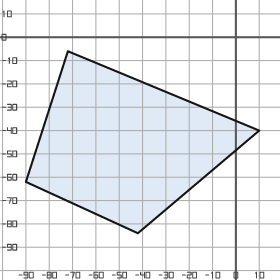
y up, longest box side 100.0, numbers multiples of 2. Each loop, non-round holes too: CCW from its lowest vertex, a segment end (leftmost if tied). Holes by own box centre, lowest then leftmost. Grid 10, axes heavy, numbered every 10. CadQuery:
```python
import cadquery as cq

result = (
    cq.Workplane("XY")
    .moveTo(-42.0, -84.0)
    .lineTo(10.0, -40.0)
    .lineTo(-72.0, -6.0)
    .lineTo(-90.0, -62.0)
    .close()
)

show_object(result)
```